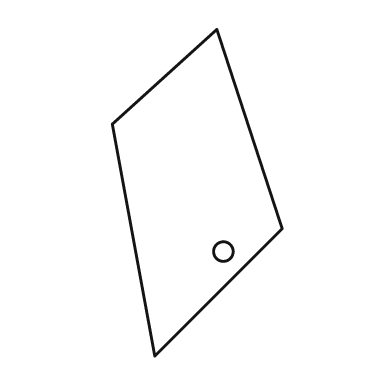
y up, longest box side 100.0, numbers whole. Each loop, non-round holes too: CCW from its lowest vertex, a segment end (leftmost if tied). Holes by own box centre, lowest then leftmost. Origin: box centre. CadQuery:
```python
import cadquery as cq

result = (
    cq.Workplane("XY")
    .moveTo(-13.0, -50.0)
    .lineTo(26.0, -11.0)
    .lineTo(6.0, 50.0)
    .lineTo(-26.0, 21.0)
    .close()
    .moveTo(8.0, -18.0)
    .circle(3.0)
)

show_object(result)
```